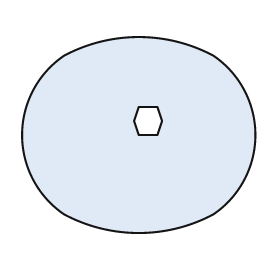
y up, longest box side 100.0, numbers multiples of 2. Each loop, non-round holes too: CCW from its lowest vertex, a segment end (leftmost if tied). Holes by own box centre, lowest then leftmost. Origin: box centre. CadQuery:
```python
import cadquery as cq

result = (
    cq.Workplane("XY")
    .moveTo(-32.0, -34.0)
    .threePointArc((0.0, -42.0), (32.0, -34.0))
    .threePointArc((50.0, 0.0), (32.0, 34.0))
    .threePointArc((0.0, 42.0), (-32.0, 34.0))
    .threePointArc((-50.0, 0.0), (-32.0, -34.0))
    .close()
    .moveTo(0.0, 0.0)
    .lineTo(8.0, 0.0)
    .lineTo(10.0, 6.0)
    .lineTo(8.0, 12.0)
    .lineTo(0.0, 12.0)
    .lineTo(-2.0, 6.0)
    .close()
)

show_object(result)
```